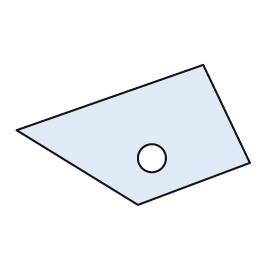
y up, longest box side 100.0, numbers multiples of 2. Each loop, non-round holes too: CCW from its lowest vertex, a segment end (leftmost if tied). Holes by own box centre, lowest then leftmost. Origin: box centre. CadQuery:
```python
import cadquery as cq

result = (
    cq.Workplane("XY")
    .moveTo(2.0, -30.0)
    .lineTo(50.0, -12.0)
    .lineTo(30.0, 30.0)
    .lineTo(-50.0, 2.0)
    .close()
    .moveTo(8.0, -10.0)
    .circle(6.0)
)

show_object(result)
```